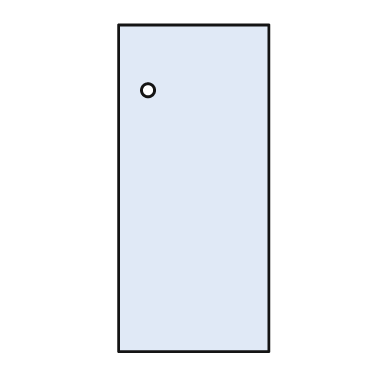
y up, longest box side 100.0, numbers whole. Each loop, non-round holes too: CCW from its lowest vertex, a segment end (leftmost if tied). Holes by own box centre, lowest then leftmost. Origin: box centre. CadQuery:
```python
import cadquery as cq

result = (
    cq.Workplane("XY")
    .moveTo(-23.0, -50.0)
    .lineTo(23.0, -50.0)
    .lineTo(23.0, 50.0)
    .lineTo(-23.0, 50.0)
    .close()
    .moveTo(-14.0, 30.0)
    .circle(2.0)
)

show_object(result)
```